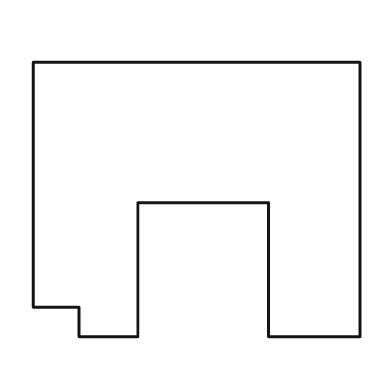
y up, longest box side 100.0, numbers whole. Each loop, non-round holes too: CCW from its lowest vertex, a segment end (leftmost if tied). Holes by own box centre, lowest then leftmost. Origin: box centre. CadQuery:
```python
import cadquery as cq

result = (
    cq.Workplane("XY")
    .moveTo(-36.0, -42.0)
    .lineTo(-18.0, -42.0)
    .lineTo(-18.0, -1.0)
    .lineTo(22.0, -1.0)
    .lineTo(22.0, -42.0)
    .lineTo(50.0, -42.0)
    .lineTo(50.0, 42.0)
    .lineTo(-50.0, 42.0)
    .lineTo(-50.0, -33.0)
    .lineTo(-36.0, -33.0)
    .close()
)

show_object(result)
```